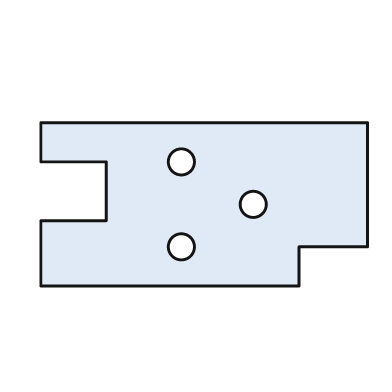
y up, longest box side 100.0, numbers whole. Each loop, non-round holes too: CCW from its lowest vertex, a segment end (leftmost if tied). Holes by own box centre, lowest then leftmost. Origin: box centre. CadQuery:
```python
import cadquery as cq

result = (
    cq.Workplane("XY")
    .moveTo(-50.0, -25.0)
    .lineTo(29.0, -25.0)
    .lineTo(29.0, -13.0)
    .lineTo(50.0, -13.0)
    .lineTo(50.0, 25.0)
    .lineTo(-50.0, 25.0)
    .lineTo(-50.0, 13.0)
    .lineTo(-30.0, 13.0)
    .lineTo(-30.0, -5.0)
    .lineTo(-50.0, -5.0)
    .close()
    .moveTo(-7.0, -13.0)
    .circle(4.0)
    .moveTo(15.0, 0.0)
    .circle(4.0)
    .moveTo(-7.0, 13.0)
    .circle(4.0)
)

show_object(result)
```